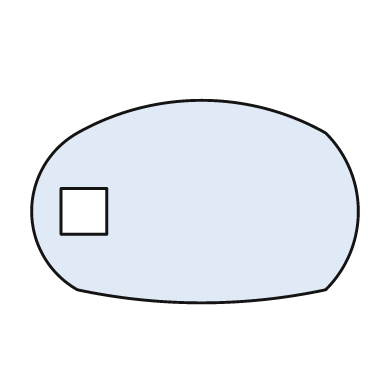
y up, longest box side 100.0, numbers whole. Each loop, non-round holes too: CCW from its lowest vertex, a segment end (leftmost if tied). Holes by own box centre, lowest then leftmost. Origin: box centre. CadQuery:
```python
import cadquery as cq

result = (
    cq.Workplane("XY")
    .moveTo(-36.0, -27.0)
    .threePointArc((2.0, -31.0), (40.0, -27.0))
    .threePointArc((50.0, -3.0), (40.0, 21.0))
    .threePointArc((2.0, 31.0), (-36.0, 21.0))
    .threePointArc((-50.0, -3.0), (-36.0, -27.0))
    .close()
    .moveTo(-41.0, -10.0)
    .lineTo(-27.0, -10.0)
    .lineTo(-27.0, 4.0)
    .lineTo(-41.0, 4.0)
    .close()
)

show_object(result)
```